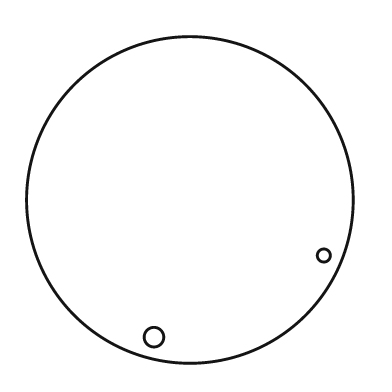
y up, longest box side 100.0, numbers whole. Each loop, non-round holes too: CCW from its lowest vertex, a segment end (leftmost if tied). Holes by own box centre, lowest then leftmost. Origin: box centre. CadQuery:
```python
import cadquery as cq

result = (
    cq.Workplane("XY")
    .moveTo(0.0, 0.0)
    .circle(50.0)
    .moveTo(-11.0, -42.0)
    .circle(3.0)
    .moveTo(41.0, -17.0)
    .circle(2.0)
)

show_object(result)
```